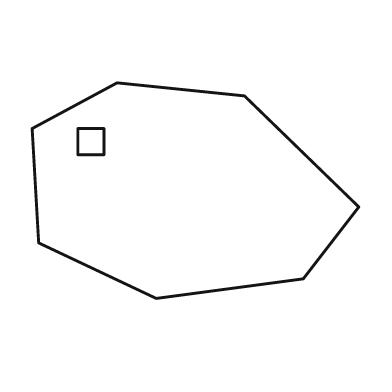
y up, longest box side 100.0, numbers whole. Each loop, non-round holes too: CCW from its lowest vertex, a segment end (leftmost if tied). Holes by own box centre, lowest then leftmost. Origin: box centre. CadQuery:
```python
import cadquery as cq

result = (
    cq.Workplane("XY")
    .moveTo(-12.0, -33.0)
    .lineTo(33.0, -27.0)
    .lineTo(50.0, -5.0)
    .lineTo(15.0, 29.0)
    .lineTo(-24.0, 33.0)
    .lineTo(-50.0, 19.0)
    .lineTo(-48.0, -16.0)
    .close()
    .moveTo(-36.0, 11.0)
    .lineTo(-28.0, 11.0)
    .lineTo(-28.0, 19.0)
    .lineTo(-36.0, 19.0)
    .close()
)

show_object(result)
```